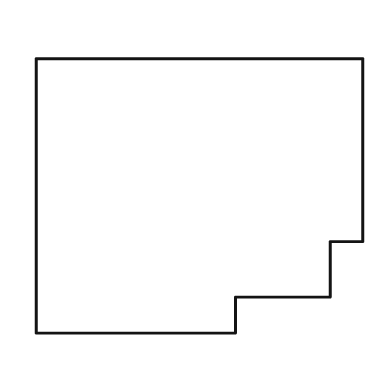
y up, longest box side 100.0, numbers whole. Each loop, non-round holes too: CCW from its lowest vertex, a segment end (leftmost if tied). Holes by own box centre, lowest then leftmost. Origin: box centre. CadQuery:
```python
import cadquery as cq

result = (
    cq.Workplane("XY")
    .moveTo(-50.0, -42.0)
    .lineTo(11.0, -42.0)
    .lineTo(11.0, -31.0)
    .lineTo(40.0, -31.0)
    .lineTo(40.0, -14.0)
    .lineTo(50.0, -14.0)
    .lineTo(50.0, 42.0)
    .lineTo(-50.0, 42.0)
    .close()
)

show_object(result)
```